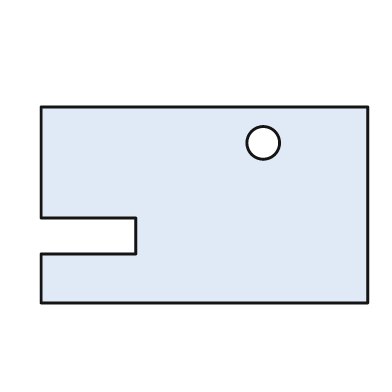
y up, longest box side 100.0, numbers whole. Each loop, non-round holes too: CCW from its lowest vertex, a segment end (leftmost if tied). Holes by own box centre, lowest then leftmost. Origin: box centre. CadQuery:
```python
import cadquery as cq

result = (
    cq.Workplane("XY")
    .moveTo(-50.0, -30.0)
    .lineTo(50.0, -30.0)
    .lineTo(50.0, 30.0)
    .lineTo(-50.0, 30.0)
    .lineTo(-50.0, -4.0)
    .lineTo(-21.0, -4.0)
    .lineTo(-21.0, -15.0)
    .lineTo(-50.0, -15.0)
    .close()
    .moveTo(18.0, 19.0)
    .circle(5.0)
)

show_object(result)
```